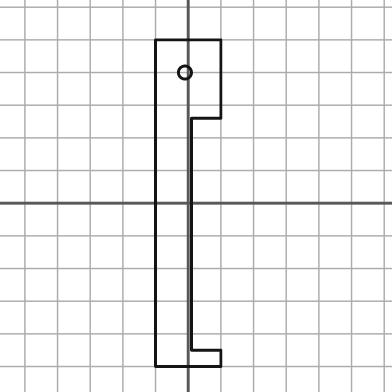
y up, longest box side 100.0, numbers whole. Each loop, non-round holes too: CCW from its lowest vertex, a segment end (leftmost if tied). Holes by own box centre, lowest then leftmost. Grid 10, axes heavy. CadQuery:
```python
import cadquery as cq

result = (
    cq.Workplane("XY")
    .moveTo(-10.0, -50.0)
    .lineTo(10.0, -50.0)
    .lineTo(10.0, -45.0)
    .lineTo(1.0, -45.0)
    .lineTo(1.0, 26.0)
    .lineTo(10.0, 26.0)
    .lineTo(10.0, 50.0)
    .lineTo(-10.0, 50.0)
    .close()
    .moveTo(-1.0, 40.0)
    .circle(2.0)
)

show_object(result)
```